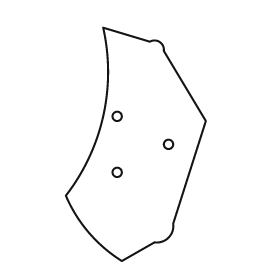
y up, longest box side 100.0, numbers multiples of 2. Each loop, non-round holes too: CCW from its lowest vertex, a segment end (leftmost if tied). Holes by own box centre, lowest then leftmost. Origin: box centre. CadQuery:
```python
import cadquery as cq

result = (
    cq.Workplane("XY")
    .moveTo(-6.0, -50.0)
    .lineTo(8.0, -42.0)
    .threePointArc((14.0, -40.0), (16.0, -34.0))
    .lineTo(30.0, 10.0)
    .lineTo(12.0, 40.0)
    .threePointArc((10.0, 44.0), (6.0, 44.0))
    .lineTo(-14.0, 50.0)
    .threePointArc((-14.0, 12.0), (-30.0, -22.0))
    .threePointArc((-20.0, -38.0), (-6.0, -50.0))
    .close()
    .moveTo(-8.0, -12.0)
    .circle(2.0)
    .moveTo(14.0, 0.0)
    .circle(2.0)
    .moveTo(-8.0, 12.0)
    .circle(2.0)
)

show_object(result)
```